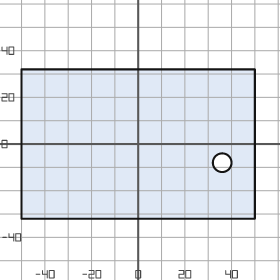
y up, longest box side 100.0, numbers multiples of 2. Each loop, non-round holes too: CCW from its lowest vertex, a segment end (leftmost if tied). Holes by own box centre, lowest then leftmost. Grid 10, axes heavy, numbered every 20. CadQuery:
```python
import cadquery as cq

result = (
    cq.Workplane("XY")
    .moveTo(-50.0, -32.0)
    .lineTo(50.0, -32.0)
    .lineTo(50.0, 32.0)
    .lineTo(-50.0, 32.0)
    .close()
    .moveTo(36.0, -8.0)
    .circle(4.0)
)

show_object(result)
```